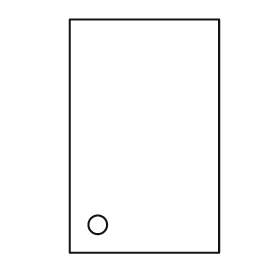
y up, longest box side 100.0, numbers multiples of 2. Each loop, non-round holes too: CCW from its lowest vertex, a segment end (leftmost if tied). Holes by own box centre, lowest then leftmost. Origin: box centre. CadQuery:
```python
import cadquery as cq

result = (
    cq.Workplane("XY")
    .moveTo(-32.0, -50.0)
    .lineTo(32.0, -50.0)
    .lineTo(32.0, 50.0)
    .lineTo(-32.0, 50.0)
    .close()
    .moveTo(-20.0, -38.0)
    .circle(4.0)
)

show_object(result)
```